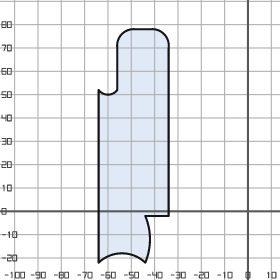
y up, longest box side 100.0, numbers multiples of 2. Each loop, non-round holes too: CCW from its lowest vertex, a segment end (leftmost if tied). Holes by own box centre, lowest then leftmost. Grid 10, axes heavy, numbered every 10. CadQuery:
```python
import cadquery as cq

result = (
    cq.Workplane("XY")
    .moveTo(-64.0, -22.0)
    .threePointArc((-54.0, -18.0), (-44.0, -22.0))
    .threePointArc((-42.0, -12.0), (-44.0, -2.0))
    .lineTo(-34.0, -2.0)
    .lineTo(-34.0, 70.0)
    .threePointArc((-36.0, 76.0), (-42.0, 78.0))
    .lineTo(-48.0, 78.0)
    .threePointArc((-54.0, 76.0), (-56.0, 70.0))
    .lineTo(-56.0, 52.0)
    .threePointArc((-60.0, 50.0), (-64.0, 52.0))
    .close()
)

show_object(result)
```